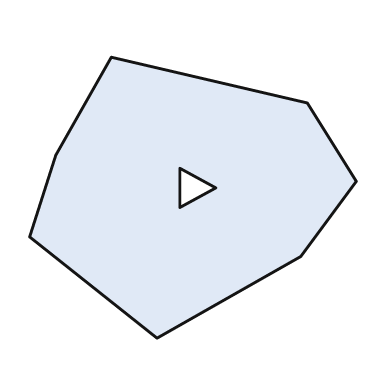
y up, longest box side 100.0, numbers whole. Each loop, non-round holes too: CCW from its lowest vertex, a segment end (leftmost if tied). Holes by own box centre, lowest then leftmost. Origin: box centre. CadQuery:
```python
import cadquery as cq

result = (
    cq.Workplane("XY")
    .moveTo(-11.0, -43.0)
    .lineTo(33.0, -18.0)
    .lineTo(50.0, 5.0)
    .lineTo(35.0, 29.0)
    .lineTo(-25.0, 43.0)
    .lineTo(-42.0, 13.0)
    .lineTo(-50.0, -12.0)
    .close()
    .moveTo(-4.0, -3.0)
    .lineTo(7.0, 3.0)
    .lineTo(-4.0, 9.0)
    .close()
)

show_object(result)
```